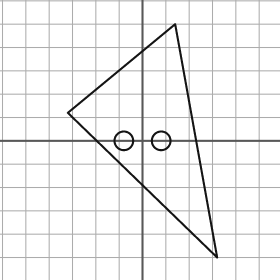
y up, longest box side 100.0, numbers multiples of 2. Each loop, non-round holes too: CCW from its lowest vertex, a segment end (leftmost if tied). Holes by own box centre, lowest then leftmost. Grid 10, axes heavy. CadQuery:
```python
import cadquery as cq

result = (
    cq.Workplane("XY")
    .moveTo(32.0, -50.0)
    .lineTo(14.0, 50.0)
    .lineTo(-32.0, 12.0)
    .close()
    .moveTo(-8.0, 0.0)
    .circle(4.0)
    .moveTo(8.0, 0.0)
    .circle(4.0)
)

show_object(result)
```